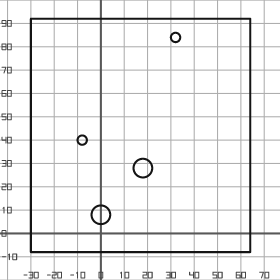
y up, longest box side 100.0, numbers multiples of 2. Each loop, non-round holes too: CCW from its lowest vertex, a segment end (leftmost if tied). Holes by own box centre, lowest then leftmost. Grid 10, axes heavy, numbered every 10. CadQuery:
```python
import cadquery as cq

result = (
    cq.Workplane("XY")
    .moveTo(-30.0, -8.0)
    .lineTo(64.0, -8.0)
    .lineTo(64.0, 92.0)
    .lineTo(-30.0, 92.0)
    .close()
    .moveTo(0.0, 8.0)
    .circle(4.0)
    .moveTo(18.0, 28.0)
    .circle(4.0)
    .moveTo(-8.0, 40.0)
    .circle(2.0)
    .moveTo(32.0, 84.0)
    .circle(2.0)
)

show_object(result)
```